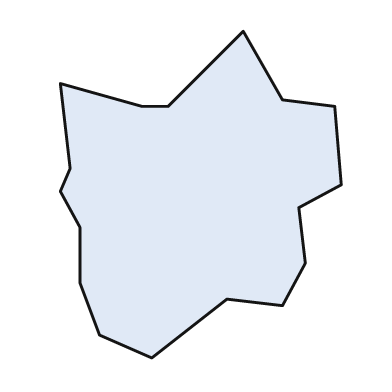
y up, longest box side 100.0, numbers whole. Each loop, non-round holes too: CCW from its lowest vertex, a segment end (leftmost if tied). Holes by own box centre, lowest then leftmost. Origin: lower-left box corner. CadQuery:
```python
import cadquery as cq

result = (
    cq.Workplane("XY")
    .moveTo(28.0, 0.0)
    .lineTo(51.0, 18.0)
    .lineTo(68.0, 16.0)
    .lineTo(75.0, 29.0)
    .lineTo(73.0, 46.0)
    .lineTo(86.0, 53.0)
    .lineTo(84.0, 77.0)
    .lineTo(68.0, 79.0)
    .lineTo(56.0, 100.0)
    .lineTo(33.0, 77.0)
    .lineTo(25.0, 77.0)
    .lineTo(0.0, 84.0)
    .lineTo(3.0, 58.0)
    .lineTo(0.0, 51.0)
    .lineTo(6.0, 40.0)
    .lineTo(6.0, 23.0)
    .lineTo(12.0, 7.0)
    .close()
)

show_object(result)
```